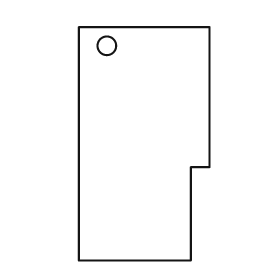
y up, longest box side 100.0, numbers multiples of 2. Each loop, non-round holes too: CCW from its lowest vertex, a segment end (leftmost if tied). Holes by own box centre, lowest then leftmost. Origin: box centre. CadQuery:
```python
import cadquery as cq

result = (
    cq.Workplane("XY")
    .moveTo(-28.0, -50.0)
    .lineTo(20.0, -50.0)
    .lineTo(20.0, -10.0)
    .lineTo(28.0, -10.0)
    .lineTo(28.0, 50.0)
    .lineTo(-28.0, 50.0)
    .close()
    .moveTo(-16.0, 42.0)
    .circle(4.0)
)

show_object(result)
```